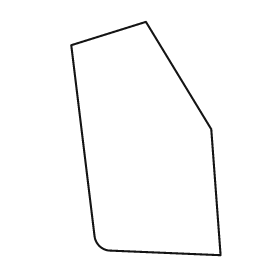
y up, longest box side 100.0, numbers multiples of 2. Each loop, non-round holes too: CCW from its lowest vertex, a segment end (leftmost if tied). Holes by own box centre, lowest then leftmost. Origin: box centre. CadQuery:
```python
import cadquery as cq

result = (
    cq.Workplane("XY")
    .moveTo(32.0, -50.0)
    .lineTo(28.0, 4.0)
    .lineTo(0.0, 50.0)
    .lineTo(-32.0, 40.0)
    .lineTo(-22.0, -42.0)
    .threePointArc((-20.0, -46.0), (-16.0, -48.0))
    .close()
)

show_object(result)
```